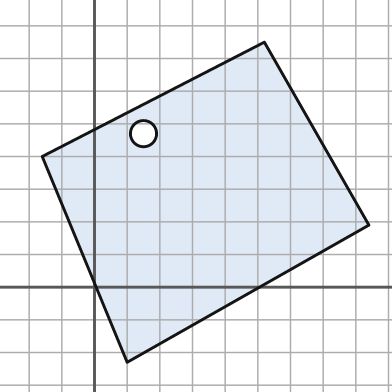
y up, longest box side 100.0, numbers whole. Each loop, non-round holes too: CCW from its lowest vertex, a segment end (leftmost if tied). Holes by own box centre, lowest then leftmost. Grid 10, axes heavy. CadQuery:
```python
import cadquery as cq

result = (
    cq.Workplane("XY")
    .moveTo(10.0, -23.0)
    .lineTo(84.0, 19.0)
    .lineTo(52.0, 75.0)
    .lineTo(-16.0, 40.0)
    .close()
    .moveTo(15.0, 47.0)
    .circle(4.0)
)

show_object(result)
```